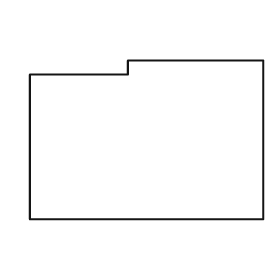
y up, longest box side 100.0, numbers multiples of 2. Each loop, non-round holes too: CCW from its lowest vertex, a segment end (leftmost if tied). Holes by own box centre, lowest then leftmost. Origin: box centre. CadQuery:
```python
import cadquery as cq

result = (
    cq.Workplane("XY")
    .moveTo(-50.0, -34.0)
    .lineTo(50.0, -34.0)
    .lineTo(50.0, 34.0)
    .lineTo(-8.0, 34.0)
    .lineTo(-8.0, 28.0)
    .lineTo(-50.0, 28.0)
    .close()
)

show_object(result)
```